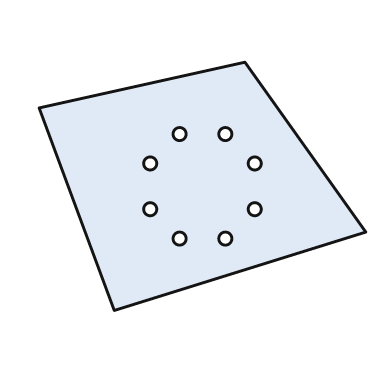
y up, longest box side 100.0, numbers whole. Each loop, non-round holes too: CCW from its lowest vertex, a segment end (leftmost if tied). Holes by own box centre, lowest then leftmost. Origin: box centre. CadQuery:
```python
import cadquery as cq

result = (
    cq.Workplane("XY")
    .moveTo(-27.0, -38.0)
    .lineTo(50.0, -14.0)
    .lineTo(13.0, 38.0)
    .lineTo(-50.0, 24.0)
    .close()
    .moveTo(-7.0, -16.0)
    .circle(2.0)
    .moveTo(7.0, -16.0)
    .circle(2.0)
    .moveTo(-16.0, -7.0)
    .circle(2.0)
    .moveTo(16.0, -7.0)
    .circle(2.0)
    .moveTo(-16.0, 7.0)
    .circle(2.0)
    .moveTo(16.0, 7.0)
    .circle(2.0)
    .moveTo(-7.0, 16.0)
    .circle(2.0)
    .moveTo(7.0, 16.0)
    .circle(2.0)
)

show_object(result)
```